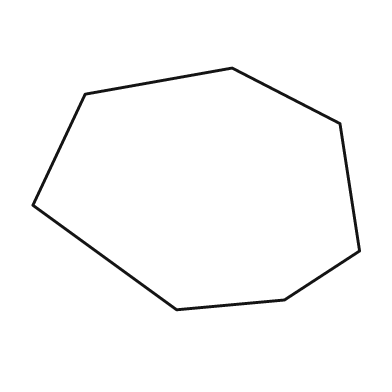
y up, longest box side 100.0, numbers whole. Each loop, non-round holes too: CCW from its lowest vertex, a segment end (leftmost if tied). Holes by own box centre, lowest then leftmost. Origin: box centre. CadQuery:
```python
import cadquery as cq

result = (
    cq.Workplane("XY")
    .moveTo(-6.0, -37.0)
    .lineTo(27.0, -34.0)
    .lineTo(50.0, -19.0)
    .lineTo(44.0, 20.0)
    .lineTo(11.0, 37.0)
    .lineTo(-34.0, 29.0)
    .lineTo(-50.0, -5.0)
    .close()
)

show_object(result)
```